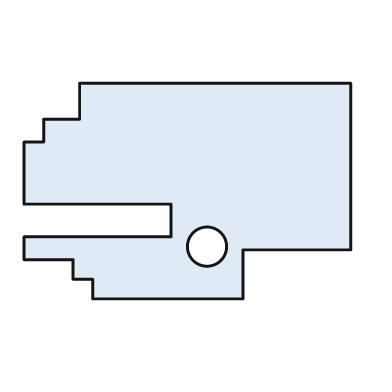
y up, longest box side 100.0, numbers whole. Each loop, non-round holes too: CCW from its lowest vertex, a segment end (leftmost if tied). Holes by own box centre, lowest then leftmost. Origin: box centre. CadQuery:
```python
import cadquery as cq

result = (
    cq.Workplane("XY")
    .moveTo(-29.0, -33.0)
    .lineTo(17.0, -33.0)
    .lineTo(17.0, -18.0)
    .lineTo(50.0, -18.0)
    .lineTo(50.0, 33.0)
    .lineTo(-33.0, 33.0)
    .lineTo(-33.0, 22.0)
    .lineTo(-44.0, 22.0)
    .lineTo(-44.0, 15.0)
    .lineTo(-50.0, 15.0)
    .lineTo(-50.0, -4.0)
    .lineTo(-5.0, -4.0)
    .lineTo(-5.0, -14.0)
    .lineTo(-50.0, -14.0)
    .lineTo(-50.0, -21.0)
    .lineTo(-35.0, -21.0)
    .lineTo(-35.0, -27.0)
    .lineTo(-29.0, -27.0)
    .close()
    .moveTo(6.0, -17.0)
    .circle(6.0)
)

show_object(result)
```